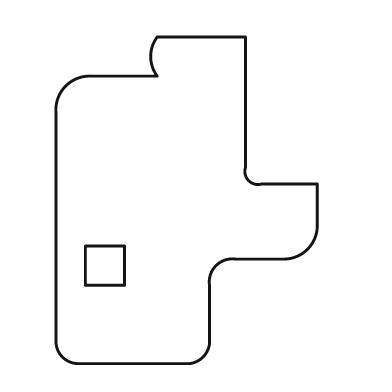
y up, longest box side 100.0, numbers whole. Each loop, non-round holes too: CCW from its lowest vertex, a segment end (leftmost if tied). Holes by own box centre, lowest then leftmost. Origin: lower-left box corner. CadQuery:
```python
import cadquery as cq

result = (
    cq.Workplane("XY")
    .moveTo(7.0, 0.0)
    .lineTo(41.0, 0.0)
    .threePointArc((45.0, 2.0), (47.0, 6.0))
    .lineTo(47.0, 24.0)
    .threePointArc((49.0, 30.0), (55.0, 32.0))
    .lineTo(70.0, 32.0)
    .threePointArc((77.0, 35.0), (80.0, 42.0))
    .lineTo(80.0, 55.0)
    .lineTo(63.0, 55.0)
    .threePointArc((59.0, 56.0), (58.0, 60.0))
    .lineTo(58.0, 100.0)
    .lineTo(31.0, 100.0)
    .threePointArc((29.0, 94.0), (31.0, 88.0))
    .lineTo(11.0, 88.0)
    .threePointArc((3.0, 85.0), (0.0, 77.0))
    .lineTo(0.0, 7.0)
    .threePointArc((2.0, 2.0), (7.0, 0.0))
    .close()
    .moveTo(9.0, 24.0)
    .lineTo(21.0, 24.0)
    .lineTo(21.0, 36.0)
    .lineTo(9.0, 36.0)
    .close()
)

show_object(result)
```